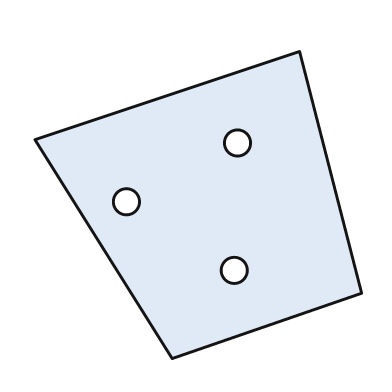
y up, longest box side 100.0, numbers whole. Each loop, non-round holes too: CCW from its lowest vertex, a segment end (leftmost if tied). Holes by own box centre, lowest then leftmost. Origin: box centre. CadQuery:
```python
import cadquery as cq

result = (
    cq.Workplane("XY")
    .moveTo(-8.0, -47.0)
    .lineTo(50.0, -27.0)
    .lineTo(31.0, 47.0)
    .lineTo(-50.0, 20.0)
    .close()
    .moveTo(11.0, -20.0)
    .circle(4.0)
    .moveTo(-22.0, 1.0)
    .circle(4.0)
    .moveTo(12.0, 19.0)
    .circle(4.0)
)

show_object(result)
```